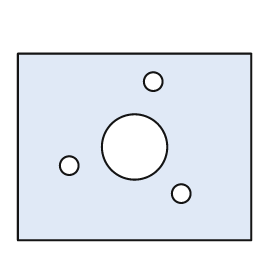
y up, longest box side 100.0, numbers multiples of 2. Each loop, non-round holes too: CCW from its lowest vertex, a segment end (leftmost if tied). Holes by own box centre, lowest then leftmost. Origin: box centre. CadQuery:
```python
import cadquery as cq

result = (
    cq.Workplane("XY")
    .moveTo(-50.0, -40.0)
    .lineTo(50.0, -40.0)
    .lineTo(50.0, 40.0)
    .lineTo(-50.0, 40.0)
    .close()
    .moveTo(20.0, -20.0)
    .circle(4.0)
    .moveTo(-28.0, -8.0)
    .circle(4.0)
    .moveTo(0.0, 0.0)
    .circle(14.0)
    .moveTo(8.0, 28.0)
    .circle(4.0)
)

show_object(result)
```